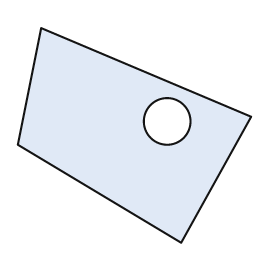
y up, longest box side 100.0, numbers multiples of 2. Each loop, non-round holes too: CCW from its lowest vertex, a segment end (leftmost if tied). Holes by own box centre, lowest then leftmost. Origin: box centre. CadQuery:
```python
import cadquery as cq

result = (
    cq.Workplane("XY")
    .moveTo(20.0, -46.0)
    .lineTo(50.0, 8.0)
    .lineTo(-40.0, 46.0)
    .lineTo(-50.0, -4.0)
    .close()
    .moveTo(14.0, 6.0)
    .circle(10.0)
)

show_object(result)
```